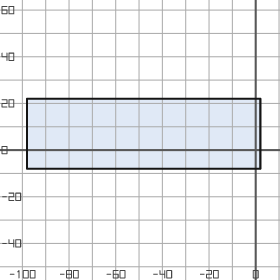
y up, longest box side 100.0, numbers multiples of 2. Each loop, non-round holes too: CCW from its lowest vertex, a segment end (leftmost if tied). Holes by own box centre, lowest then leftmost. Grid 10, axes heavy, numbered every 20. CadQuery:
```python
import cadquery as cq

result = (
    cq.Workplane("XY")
    .moveTo(-98.0, -8.0)
    .lineTo(2.0, -8.0)
    .lineTo(2.0, 22.0)
    .lineTo(-98.0, 22.0)
    .close()
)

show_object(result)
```